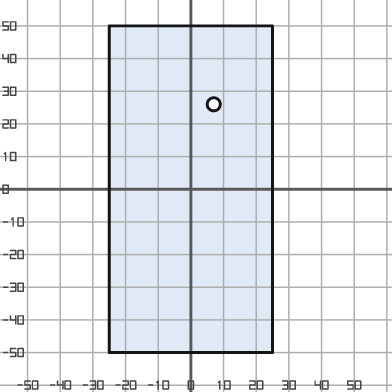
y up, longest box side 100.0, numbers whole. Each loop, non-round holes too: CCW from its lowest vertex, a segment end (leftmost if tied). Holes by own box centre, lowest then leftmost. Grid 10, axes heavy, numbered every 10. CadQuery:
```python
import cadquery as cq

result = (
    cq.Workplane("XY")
    .moveTo(-25.0, -50.0)
    .lineTo(25.0, -50.0)
    .lineTo(25.0, 50.0)
    .lineTo(-25.0, 50.0)
    .close()
    .moveTo(7.0, 26.0)
    .circle(2.0)
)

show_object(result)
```